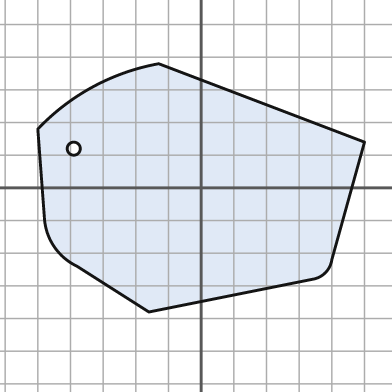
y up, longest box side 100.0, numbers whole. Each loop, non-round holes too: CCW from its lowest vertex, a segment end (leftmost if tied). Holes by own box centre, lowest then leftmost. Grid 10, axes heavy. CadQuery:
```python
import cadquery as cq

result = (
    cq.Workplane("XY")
    .moveTo(-16.0, -38.0)
    .lineTo(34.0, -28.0)
    .threePointArc((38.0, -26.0), (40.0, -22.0))
    .lineTo(50.0, 14.0)
    .lineTo(-13.0, 38.0)
    .threePointArc((-33.0, 31.0), (-50.0, 18.0))
    .lineTo(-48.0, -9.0)
    .threePointArc((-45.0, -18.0), (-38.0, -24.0))
    .close()
    .moveTo(-39.0, 12.0)
    .circle(2.0)
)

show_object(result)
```